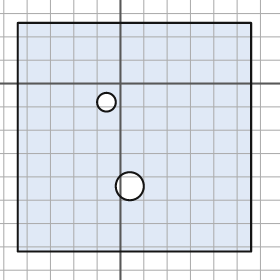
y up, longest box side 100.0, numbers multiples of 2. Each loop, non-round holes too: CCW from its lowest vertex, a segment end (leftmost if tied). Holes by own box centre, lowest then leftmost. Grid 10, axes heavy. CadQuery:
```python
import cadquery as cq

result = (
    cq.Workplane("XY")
    .moveTo(-44.0, -72.0)
    .lineTo(56.0, -72.0)
    .lineTo(56.0, 26.0)
    .lineTo(-44.0, 26.0)
    .close()
    .moveTo(4.0, -44.0)
    .circle(6.0)
    .moveTo(-6.0, -8.0)
    .circle(4.0)
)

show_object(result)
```